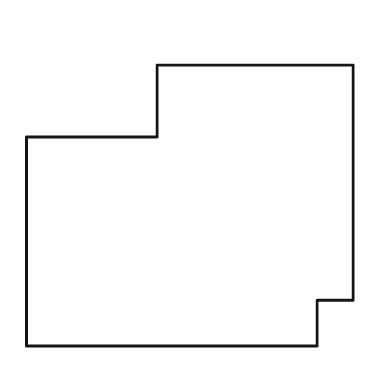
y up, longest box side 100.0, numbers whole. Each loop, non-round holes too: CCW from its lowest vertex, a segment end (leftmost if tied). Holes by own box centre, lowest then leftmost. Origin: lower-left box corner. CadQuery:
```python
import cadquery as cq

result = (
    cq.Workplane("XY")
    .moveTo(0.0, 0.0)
    .lineTo(89.0, 0.0)
    .lineTo(89.0, 14.0)
    .lineTo(100.0, 14.0)
    .lineTo(100.0, 86.0)
    .lineTo(40.0, 86.0)
    .lineTo(40.0, 64.0)
    .lineTo(0.0, 64.0)
    .close()
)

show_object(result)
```